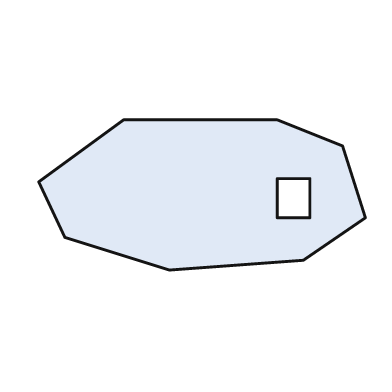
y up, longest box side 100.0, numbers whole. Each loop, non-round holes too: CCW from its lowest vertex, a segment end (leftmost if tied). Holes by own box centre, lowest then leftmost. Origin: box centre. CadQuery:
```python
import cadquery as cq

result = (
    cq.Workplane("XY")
    .moveTo(-10.0, -23.0)
    .lineTo(31.0, -20.0)
    .lineTo(50.0, -7.0)
    .lineTo(43.0, 15.0)
    .lineTo(23.0, 23.0)
    .lineTo(-24.0, 23.0)
    .lineTo(-50.0, 4.0)
    .lineTo(-42.0, -13.0)
    .close()
    .moveTo(23.0, -7.0)
    .lineTo(33.0, -7.0)
    .lineTo(33.0, 5.0)
    .lineTo(23.0, 5.0)
    .close()
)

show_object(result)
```